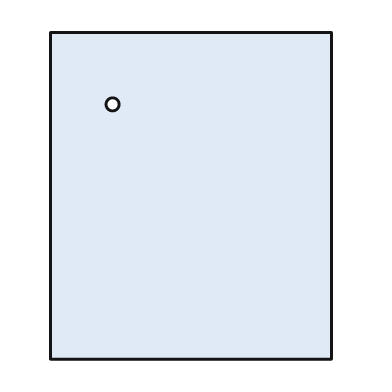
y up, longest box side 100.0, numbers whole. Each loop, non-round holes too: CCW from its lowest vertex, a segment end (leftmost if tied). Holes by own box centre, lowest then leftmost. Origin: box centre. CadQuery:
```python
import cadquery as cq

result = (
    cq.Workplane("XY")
    .moveTo(-43.0, -50.0)
    .lineTo(43.0, -50.0)
    .lineTo(43.0, 50.0)
    .lineTo(-43.0, 50.0)
    .close()
    .moveTo(-24.0, 28.0)
    .circle(2.0)
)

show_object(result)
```